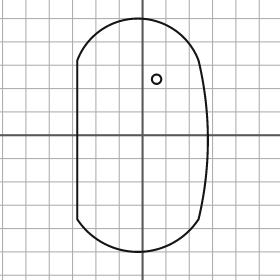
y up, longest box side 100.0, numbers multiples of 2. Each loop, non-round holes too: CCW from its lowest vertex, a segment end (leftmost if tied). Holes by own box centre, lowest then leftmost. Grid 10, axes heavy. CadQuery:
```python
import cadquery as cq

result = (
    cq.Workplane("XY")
    .moveTo(-28.0, -36.0)
    .threePointArc((-2.0, -50.0), (24.0, -36.0))
    .threePointArc((28.0, -2.0), (24.0, 32.0))
    .threePointArc((-2.0, 50.0), (-28.0, 32.0))
    .close()
    .moveTo(6.0, 24.0)
    .circle(2.0)
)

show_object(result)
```